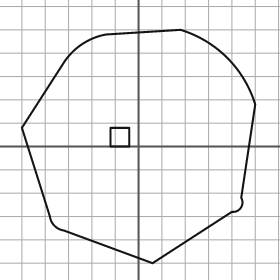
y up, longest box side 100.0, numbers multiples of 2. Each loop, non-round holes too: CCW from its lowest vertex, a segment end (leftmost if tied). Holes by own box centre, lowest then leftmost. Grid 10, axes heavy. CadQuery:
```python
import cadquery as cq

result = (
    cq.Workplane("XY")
    .moveTo(6.0, -50.0)
    .lineTo(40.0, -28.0)
    .threePointArc((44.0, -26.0), (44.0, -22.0))
    .lineTo(50.0, 18.0)
    .threePointArc((38.0, 38.0), (18.0, 50.0))
    .lineTo(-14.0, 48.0)
    .threePointArc((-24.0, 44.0), (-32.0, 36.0))
    .lineTo(-50.0, 8.0)
    .lineTo(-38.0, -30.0)
    .threePointArc((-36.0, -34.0), (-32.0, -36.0))
    .close()
    .moveTo(-12.0, 0.0)
    .lineTo(-4.0, 0.0)
    .lineTo(-4.0, 8.0)
    .lineTo(-12.0, 8.0)
    .close()
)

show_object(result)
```